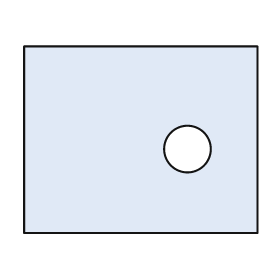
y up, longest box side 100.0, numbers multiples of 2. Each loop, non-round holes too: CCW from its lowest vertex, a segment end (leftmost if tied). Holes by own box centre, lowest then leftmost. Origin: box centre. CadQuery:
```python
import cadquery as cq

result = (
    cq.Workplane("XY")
    .moveTo(-50.0, -40.0)
    .lineTo(50.0, -40.0)
    .lineTo(50.0, 40.0)
    .lineTo(-50.0, 40.0)
    .close()
    .moveTo(20.0, -4.0)
    .circle(10.0)
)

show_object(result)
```